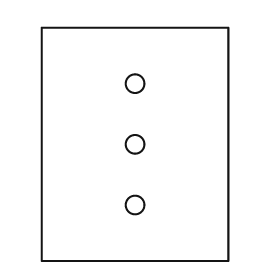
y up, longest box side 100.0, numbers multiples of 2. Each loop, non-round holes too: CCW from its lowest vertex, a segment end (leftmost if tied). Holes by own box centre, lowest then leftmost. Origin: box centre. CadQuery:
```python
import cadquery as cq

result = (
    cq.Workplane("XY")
    .moveTo(-40.0, -50.0)
    .lineTo(40.0, -50.0)
    .lineTo(40.0, 50.0)
    .lineTo(-40.0, 50.0)
    .close()
    .moveTo(0.0, -26.0)
    .circle(4.0)
    .moveTo(0.0, 0.0)
    .circle(4.0)
    .moveTo(0.0, 26.0)
    .circle(4.0)
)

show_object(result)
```